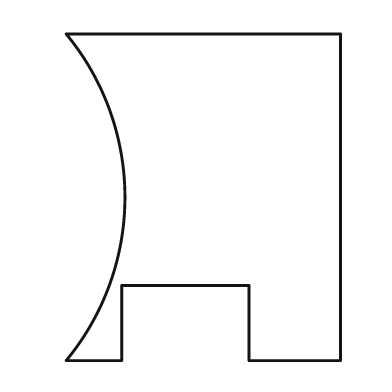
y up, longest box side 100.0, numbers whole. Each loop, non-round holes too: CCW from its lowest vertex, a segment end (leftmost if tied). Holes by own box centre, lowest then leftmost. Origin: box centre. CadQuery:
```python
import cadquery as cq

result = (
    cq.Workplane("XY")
    .moveTo(-42.0, -50.0)
    .lineTo(-25.0, -50.0)
    .lineTo(-25.0, -27.0)
    .lineTo(14.0, -27.0)
    .lineTo(14.0, -50.0)
    .lineTo(42.0, -50.0)
    .lineTo(42.0, 50.0)
    .lineTo(-42.0, 50.0)
    .threePointArc((-24.0, 0.0), (-42.0, -50.0))
    .close()
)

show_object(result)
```